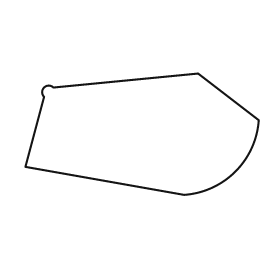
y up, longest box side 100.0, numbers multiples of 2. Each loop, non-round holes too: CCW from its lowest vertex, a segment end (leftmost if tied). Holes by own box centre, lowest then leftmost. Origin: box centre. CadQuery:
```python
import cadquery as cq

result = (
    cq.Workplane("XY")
    .moveTo(18.0, -26.0)
    .threePointArc((40.0, -16.0), (50.0, 6.0))
    .lineTo(24.0, 26.0)
    .lineTo(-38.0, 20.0)
    .threePointArc((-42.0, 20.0), (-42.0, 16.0))
    .lineTo(-50.0, -14.0)
    .close()
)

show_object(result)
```